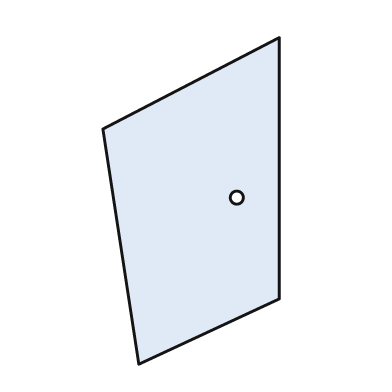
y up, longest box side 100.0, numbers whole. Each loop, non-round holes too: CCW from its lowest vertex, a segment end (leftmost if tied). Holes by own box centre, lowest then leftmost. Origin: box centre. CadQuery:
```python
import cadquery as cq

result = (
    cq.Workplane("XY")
    .moveTo(-16.0, -50.0)
    .lineTo(27.0, -30.0)
    .lineTo(27.0, 50.0)
    .lineTo(-27.0, 22.0)
    .close()
    .moveTo(14.0, 1.0)
    .circle(2.0)
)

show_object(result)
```